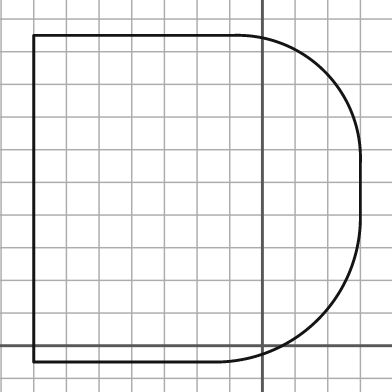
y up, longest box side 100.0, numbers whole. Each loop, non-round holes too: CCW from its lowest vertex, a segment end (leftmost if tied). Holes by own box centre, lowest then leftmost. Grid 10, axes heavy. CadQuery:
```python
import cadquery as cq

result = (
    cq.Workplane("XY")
    .moveTo(-70.0, -5.0)
    .lineTo(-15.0, -5.0)
    .threePointArc((17.0, 8.0), (30.0, 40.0))
    .lineTo(30.0, 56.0)
    .threePointArc((19.0, 84.0), (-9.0, 95.0))
    .lineTo(-70.0, 95.0)
    .close()
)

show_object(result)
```